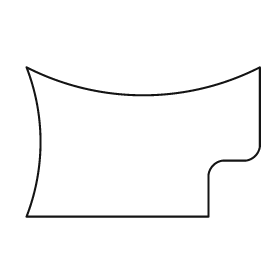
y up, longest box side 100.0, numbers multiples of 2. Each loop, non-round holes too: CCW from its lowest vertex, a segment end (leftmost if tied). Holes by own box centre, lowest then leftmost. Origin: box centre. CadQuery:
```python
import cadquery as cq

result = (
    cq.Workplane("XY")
    .moveTo(-50.0, -32.0)
    .lineTo(28.0, -32.0)
    .lineTo(28.0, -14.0)
    .threePointArc((30.0, -10.0), (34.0, -8.0))
    .lineTo(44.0, -8.0)
    .threePointArc((48.0, -6.0), (50.0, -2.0))
    .lineTo(50.0, 32.0)
    .threePointArc((0.0, 20.0), (-50.0, 32.0))
    .threePointArc((-44.0, 0.0), (-50.0, -32.0))
    .close()
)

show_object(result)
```